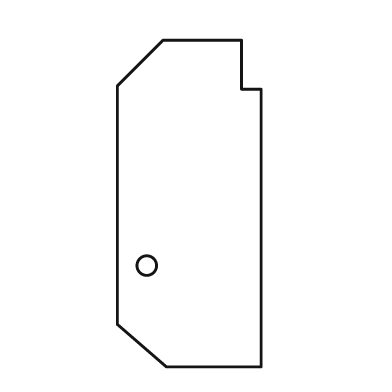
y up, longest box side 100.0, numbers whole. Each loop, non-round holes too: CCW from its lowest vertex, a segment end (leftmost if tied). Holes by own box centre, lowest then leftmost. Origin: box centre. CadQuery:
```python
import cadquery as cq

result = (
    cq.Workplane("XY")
    .moveTo(-7.0, -50.0)
    .lineTo(22.0, -50.0)
    .lineTo(22.0, 35.0)
    .lineTo(16.0, 35.0)
    .lineTo(16.0, 50.0)
    .lineTo(-8.0, 50.0)
    .lineTo(-22.0, 36.0)
    .lineTo(-22.0, -37.0)
    .close()
    .moveTo(-13.0, -19.0)
    .circle(3.0)
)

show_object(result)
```